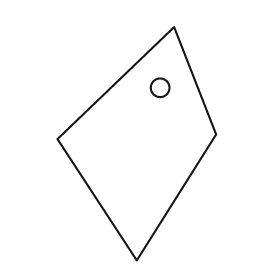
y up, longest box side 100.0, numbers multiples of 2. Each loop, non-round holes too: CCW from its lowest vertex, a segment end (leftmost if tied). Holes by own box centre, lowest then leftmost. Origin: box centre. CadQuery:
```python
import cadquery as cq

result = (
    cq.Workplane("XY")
    .moveTo(0.0, -50.0)
    .lineTo(34.0, 4.0)
    .lineTo(16.0, 50.0)
    .lineTo(-34.0, 2.0)
    .close()
    .moveTo(10.0, 24.0)
    .circle(4.0)
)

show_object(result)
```